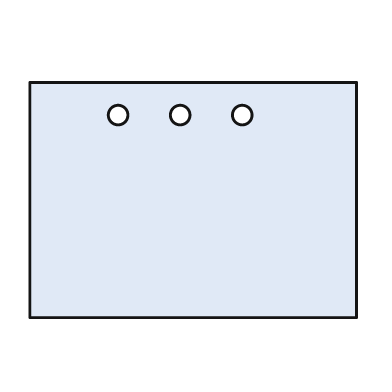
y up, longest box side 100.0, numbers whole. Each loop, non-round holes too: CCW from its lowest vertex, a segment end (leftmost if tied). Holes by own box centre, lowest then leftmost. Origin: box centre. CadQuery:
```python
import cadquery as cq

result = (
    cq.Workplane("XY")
    .moveTo(-50.0, -36.0)
    .lineTo(50.0, -36.0)
    .lineTo(50.0, 36.0)
    .lineTo(-50.0, 36.0)
    .close()
    .moveTo(-23.0, 26.0)
    .circle(3.0)
    .moveTo(-4.0, 26.0)
    .circle(3.0)
    .moveTo(15.0, 26.0)
    .circle(3.0)
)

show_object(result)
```